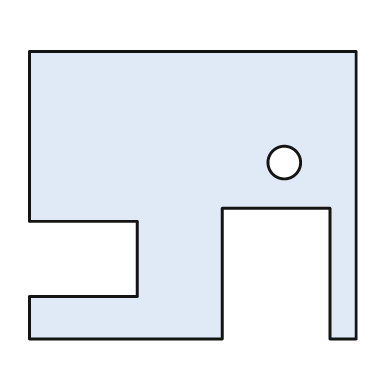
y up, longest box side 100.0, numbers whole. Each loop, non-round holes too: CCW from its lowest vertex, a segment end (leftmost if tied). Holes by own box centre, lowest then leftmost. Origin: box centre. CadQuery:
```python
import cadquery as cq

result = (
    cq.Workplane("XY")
    .moveTo(-50.0, -44.0)
    .lineTo(9.0, -44.0)
    .lineTo(9.0, -4.0)
    .lineTo(42.0, -4.0)
    .lineTo(42.0, -44.0)
    .lineTo(50.0, -44.0)
    .lineTo(50.0, 44.0)
    .lineTo(-50.0, 44.0)
    .lineTo(-50.0, -8.0)
    .lineTo(-17.0, -8.0)
    .lineTo(-17.0, -31.0)
    .lineTo(-50.0, -31.0)
    .close()
    .moveTo(28.0, 10.0)
    .circle(5.0)
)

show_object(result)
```